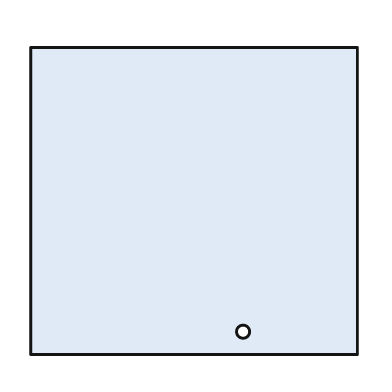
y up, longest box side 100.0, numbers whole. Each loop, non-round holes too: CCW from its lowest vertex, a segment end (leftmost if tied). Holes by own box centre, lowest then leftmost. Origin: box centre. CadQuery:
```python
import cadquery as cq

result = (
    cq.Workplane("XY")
    .moveTo(-50.0, -47.0)
    .lineTo(50.0, -47.0)
    .lineTo(50.0, 47.0)
    .lineTo(-50.0, 47.0)
    .close()
    .moveTo(15.0, -40.0)
    .circle(2.0)
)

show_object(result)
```